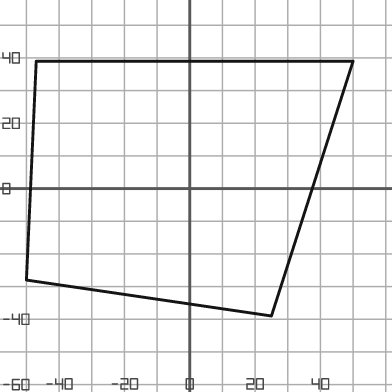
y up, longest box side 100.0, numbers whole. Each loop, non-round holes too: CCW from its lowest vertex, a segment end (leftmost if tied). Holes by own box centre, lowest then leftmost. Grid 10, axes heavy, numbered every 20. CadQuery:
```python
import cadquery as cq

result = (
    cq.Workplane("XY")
    .moveTo(25.0, -39.0)
    .lineTo(50.0, 39.0)
    .lineTo(-47.0, 39.0)
    .lineTo(-50.0, -28.0)
    .close()
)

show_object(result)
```